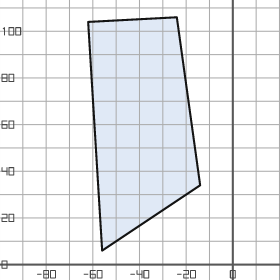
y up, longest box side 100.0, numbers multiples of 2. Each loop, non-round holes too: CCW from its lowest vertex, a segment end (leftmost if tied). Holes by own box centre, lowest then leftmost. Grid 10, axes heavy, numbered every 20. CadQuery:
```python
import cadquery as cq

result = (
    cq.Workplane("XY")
    .moveTo(-56.0, 6.0)
    .lineTo(-14.0, 34.0)
    .lineTo(-24.0, 106.0)
    .lineTo(-62.0, 104.0)
    .close()
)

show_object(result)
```